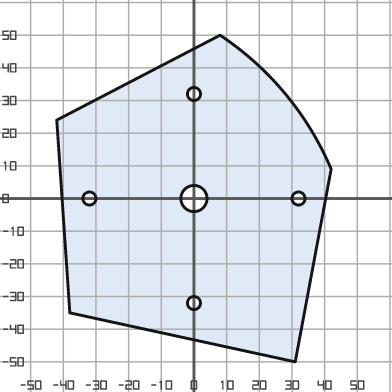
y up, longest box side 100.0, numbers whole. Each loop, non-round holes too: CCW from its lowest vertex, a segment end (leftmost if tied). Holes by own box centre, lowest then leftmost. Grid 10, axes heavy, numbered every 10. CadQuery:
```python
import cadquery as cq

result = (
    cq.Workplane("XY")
    .moveTo(31.0, -50.0)
    .lineTo(42.0, 9.0)
    .threePointArc((28.0, 32.0), (8.0, 50.0))
    .lineTo(-42.0, 24.0)
    .lineTo(-38.0, -35.0)
    .close()
    .moveTo(0.0, -32.0)
    .circle(2.0)
    .moveTo(-32.0, 0.0)
    .circle(2.0)
    .moveTo(0.0, 0.0)
    .circle(4.0)
    .moveTo(32.0, 0.0)
    .circle(2.0)
    .moveTo(0.0, 32.0)
    .circle(2.0)
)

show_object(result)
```